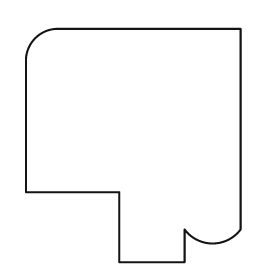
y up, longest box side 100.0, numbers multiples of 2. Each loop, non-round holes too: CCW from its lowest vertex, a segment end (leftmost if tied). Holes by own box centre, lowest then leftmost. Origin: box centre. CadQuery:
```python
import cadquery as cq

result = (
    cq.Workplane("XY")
    .moveTo(-6.0, -50.0)
    .lineTo(22.0, -50.0)
    .lineTo(22.0, -36.0)
    .threePointArc((34.0, -42.0), (46.0, -36.0))
    .lineTo(46.0, 50.0)
    .lineTo(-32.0, 50.0)
    .threePointArc((-42.0, 46.0), (-46.0, 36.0))
    .lineTo(-46.0, -20.0)
    .lineTo(-6.0, -20.0)
    .close()
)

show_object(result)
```